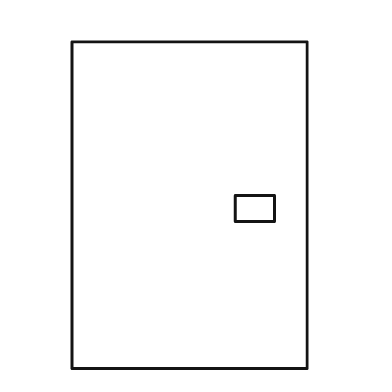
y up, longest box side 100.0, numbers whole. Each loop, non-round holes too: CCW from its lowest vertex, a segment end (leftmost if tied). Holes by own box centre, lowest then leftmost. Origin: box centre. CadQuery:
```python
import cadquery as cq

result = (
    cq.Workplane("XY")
    .moveTo(-36.0, -50.0)
    .lineTo(36.0, -50.0)
    .lineTo(36.0, 50.0)
    .lineTo(-36.0, 50.0)
    .close()
    .moveTo(14.0, -5.0)
    .lineTo(26.0, -5.0)
    .lineTo(26.0, 3.0)
    .lineTo(14.0, 3.0)
    .close()
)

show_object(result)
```